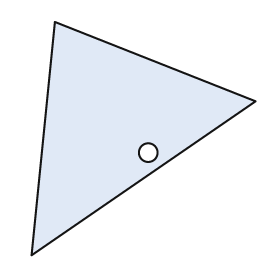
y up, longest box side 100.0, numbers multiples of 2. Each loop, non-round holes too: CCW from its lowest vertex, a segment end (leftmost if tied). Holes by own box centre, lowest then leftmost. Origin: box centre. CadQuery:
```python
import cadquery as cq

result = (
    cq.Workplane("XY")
    .moveTo(-48.0, -50.0)
    .lineTo(48.0, 16.0)
    .lineTo(-38.0, 50.0)
    .close()
    .moveTo(2.0, -6.0)
    .circle(4.0)
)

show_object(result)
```